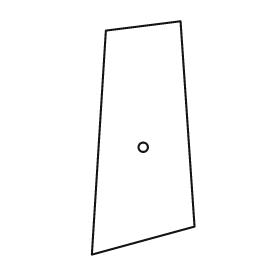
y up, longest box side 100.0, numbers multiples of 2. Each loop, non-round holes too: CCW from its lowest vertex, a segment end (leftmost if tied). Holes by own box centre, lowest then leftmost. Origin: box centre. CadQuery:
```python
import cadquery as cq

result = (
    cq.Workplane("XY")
    .moveTo(-22.0, -50.0)
    .lineTo(22.0, -38.0)
    .lineTo(16.0, 50.0)
    .lineTo(-16.0, 46.0)
    .close()
    .moveTo(0.0, -4.0)
    .circle(2.0)
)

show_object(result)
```